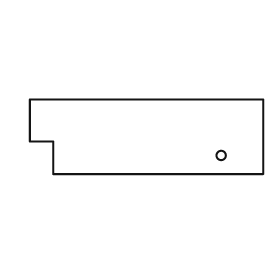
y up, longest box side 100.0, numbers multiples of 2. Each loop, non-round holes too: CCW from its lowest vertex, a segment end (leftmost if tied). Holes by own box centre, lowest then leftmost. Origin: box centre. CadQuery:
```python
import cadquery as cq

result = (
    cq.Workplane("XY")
    .moveTo(-40.0, -16.0)
    .lineTo(50.0, -16.0)
    .lineTo(50.0, 16.0)
    .lineTo(-50.0, 16.0)
    .lineTo(-50.0, -2.0)
    .lineTo(-40.0, -2.0)
    .close()
    .moveTo(32.0, -8.0)
    .circle(2.0)
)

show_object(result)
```